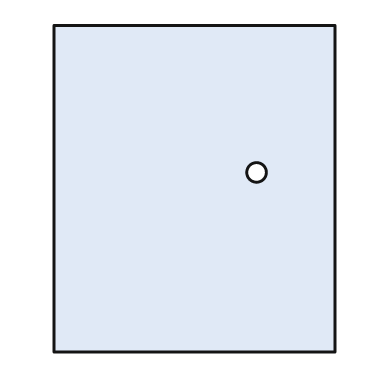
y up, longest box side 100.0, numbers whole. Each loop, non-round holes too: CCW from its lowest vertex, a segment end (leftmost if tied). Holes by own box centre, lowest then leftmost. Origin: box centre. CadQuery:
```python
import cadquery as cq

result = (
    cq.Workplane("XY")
    .moveTo(-43.0, -50.0)
    .lineTo(43.0, -50.0)
    .lineTo(43.0, 50.0)
    .lineTo(-43.0, 50.0)
    .close()
    .moveTo(19.0, 5.0)
    .circle(3.0)
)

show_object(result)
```